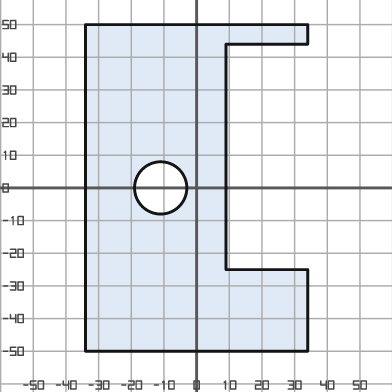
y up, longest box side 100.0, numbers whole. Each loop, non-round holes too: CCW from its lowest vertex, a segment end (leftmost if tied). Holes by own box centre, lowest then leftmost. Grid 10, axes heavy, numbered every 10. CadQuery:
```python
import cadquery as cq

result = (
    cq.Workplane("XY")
    .moveTo(-34.0, -50.0)
    .lineTo(34.0, -50.0)
    .lineTo(34.0, -25.0)
    .lineTo(9.0, -25.0)
    .lineTo(9.0, 44.0)
    .lineTo(34.0, 44.0)
    .lineTo(34.0, 50.0)
    .lineTo(-34.0, 50.0)
    .close()
    .moveTo(-11.0, 0.0)
    .circle(8.0)
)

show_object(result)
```